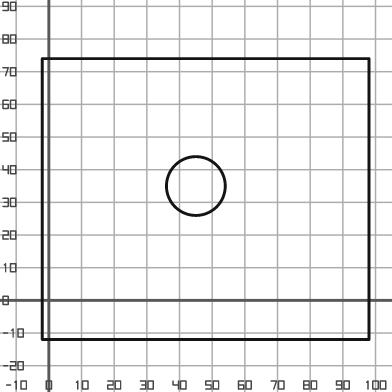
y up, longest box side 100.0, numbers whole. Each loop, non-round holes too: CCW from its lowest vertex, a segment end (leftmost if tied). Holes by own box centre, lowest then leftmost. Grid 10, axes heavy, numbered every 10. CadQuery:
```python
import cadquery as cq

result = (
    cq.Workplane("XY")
    .moveTo(-2.0, -12.0)
    .lineTo(98.0, -12.0)
    .lineTo(98.0, 74.0)
    .lineTo(-2.0, 74.0)
    .close()
    .moveTo(45.0, 35.0)
    .circle(9.0)
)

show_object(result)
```